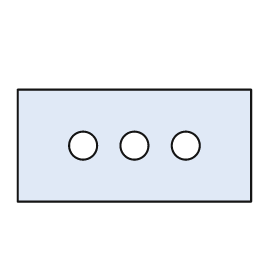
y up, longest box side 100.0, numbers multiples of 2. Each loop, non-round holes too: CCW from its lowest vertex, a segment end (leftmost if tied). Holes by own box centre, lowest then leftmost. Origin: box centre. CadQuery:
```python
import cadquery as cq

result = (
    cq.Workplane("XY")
    .moveTo(-50.0, -24.0)
    .lineTo(50.0, -24.0)
    .lineTo(50.0, 24.0)
    .lineTo(-50.0, 24.0)
    .close()
    .moveTo(-22.0, 0.0)
    .circle(6.0)
    .moveTo(0.0, 0.0)
    .circle(6.0)
    .moveTo(22.0, 0.0)
    .circle(6.0)
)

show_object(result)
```